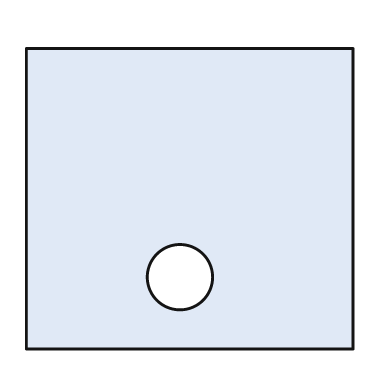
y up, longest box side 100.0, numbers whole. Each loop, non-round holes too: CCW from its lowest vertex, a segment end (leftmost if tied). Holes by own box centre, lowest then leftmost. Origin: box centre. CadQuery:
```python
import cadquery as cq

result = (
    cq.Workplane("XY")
    .moveTo(-50.0, -46.0)
    .lineTo(50.0, -46.0)
    .lineTo(50.0, 46.0)
    .lineTo(-50.0, 46.0)
    .close()
    .moveTo(-3.0, -24.0)
    .circle(10.0)
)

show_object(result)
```